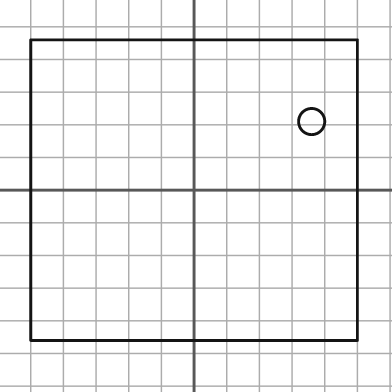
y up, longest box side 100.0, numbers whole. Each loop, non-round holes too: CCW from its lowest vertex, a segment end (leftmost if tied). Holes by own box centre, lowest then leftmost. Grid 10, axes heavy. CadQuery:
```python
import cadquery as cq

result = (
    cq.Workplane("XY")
    .moveTo(-50.0, -46.0)
    .lineTo(50.0, -46.0)
    .lineTo(50.0, 46.0)
    .lineTo(-50.0, 46.0)
    .close()
    .moveTo(36.0, 21.0)
    .circle(4.0)
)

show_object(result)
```